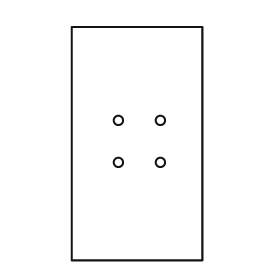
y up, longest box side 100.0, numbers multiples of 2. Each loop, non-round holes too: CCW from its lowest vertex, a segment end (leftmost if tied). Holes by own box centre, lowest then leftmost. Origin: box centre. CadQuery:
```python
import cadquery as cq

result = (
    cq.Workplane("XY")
    .moveTo(-28.0, -50.0)
    .lineTo(28.0, -50.0)
    .lineTo(28.0, 50.0)
    .lineTo(-28.0, 50.0)
    .close()
    .moveTo(-8.0, -8.0)
    .circle(2.0)
    .moveTo(10.0, -8.0)
    .circle(2.0)
    .moveTo(-8.0, 10.0)
    .circle(2.0)
    .moveTo(10.0, 10.0)
    .circle(2.0)
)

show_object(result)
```